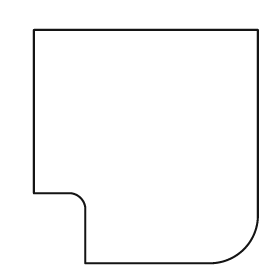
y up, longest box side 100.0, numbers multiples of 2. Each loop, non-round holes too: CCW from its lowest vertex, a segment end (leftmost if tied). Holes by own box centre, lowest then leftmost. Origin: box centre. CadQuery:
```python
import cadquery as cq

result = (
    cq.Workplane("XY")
    .moveTo(-26.0, -50.0)
    .lineTo(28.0, -50.0)
    .threePointArc((42.0, -44.0), (48.0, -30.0))
    .lineTo(48.0, 50.0)
    .lineTo(-48.0, 50.0)
    .lineTo(-48.0, -20.0)
    .lineTo(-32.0, -20.0)
    .threePointArc((-28.0, -22.0), (-26.0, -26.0))
    .close()
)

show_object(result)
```